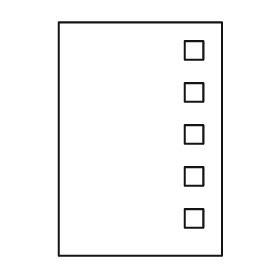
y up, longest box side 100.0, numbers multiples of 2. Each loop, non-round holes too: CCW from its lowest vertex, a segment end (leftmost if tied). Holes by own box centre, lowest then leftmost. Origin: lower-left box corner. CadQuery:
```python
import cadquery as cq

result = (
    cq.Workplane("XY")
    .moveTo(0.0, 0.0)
    .lineTo(70.0, 0.0)
    .lineTo(70.0, 100.0)
    .lineTo(0.0, 100.0)
    .close()
    .moveTo(54.0, 12.0)
    .lineTo(62.0, 12.0)
    .lineTo(62.0, 20.0)
    .lineTo(54.0, 20.0)
    .close()
    .moveTo(54.0, 30.0)
    .lineTo(62.0, 30.0)
    .lineTo(62.0, 38.0)
    .lineTo(54.0, 38.0)
    .close()
    .moveTo(54.0, 48.0)
    .lineTo(62.0, 48.0)
    .lineTo(62.0, 56.0)
    .lineTo(54.0, 56.0)
    .close()
    .moveTo(54.0, 66.0)
    .lineTo(62.0, 66.0)
    .lineTo(62.0, 74.0)
    .lineTo(54.0, 74.0)
    .close()
    .moveTo(54.0, 84.0)
    .lineTo(62.0, 84.0)
    .lineTo(62.0, 92.0)
    .lineTo(54.0, 92.0)
    .close()
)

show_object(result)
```